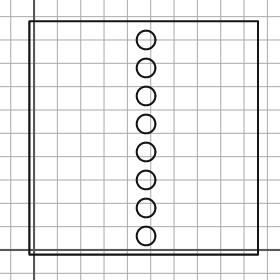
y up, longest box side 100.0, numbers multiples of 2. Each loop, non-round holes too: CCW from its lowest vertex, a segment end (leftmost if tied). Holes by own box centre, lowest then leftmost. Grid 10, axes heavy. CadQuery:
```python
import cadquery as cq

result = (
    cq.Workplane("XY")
    .moveTo(-2.0, -2.0)
    .lineTo(96.0, -2.0)
    .lineTo(96.0, 98.0)
    .lineTo(-2.0, 98.0)
    .close()
    .moveTo(48.0, 6.0)
    .circle(4.0)
    .moveTo(48.0, 18.0)
    .circle(4.0)
    .moveTo(48.0, 30.0)
    .circle(4.0)
    .moveTo(48.0, 42.0)
    .circle(4.0)
    .moveTo(48.0, 54.0)
    .circle(4.0)
    .moveTo(48.0, 66.0)
    .circle(4.0)
    .moveTo(48.0, 78.0)
    .circle(4.0)
    .moveTo(48.0, 90.0)
    .circle(4.0)
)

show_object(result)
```